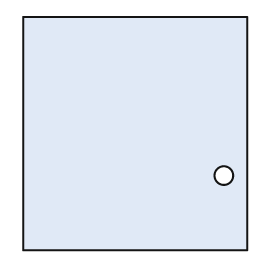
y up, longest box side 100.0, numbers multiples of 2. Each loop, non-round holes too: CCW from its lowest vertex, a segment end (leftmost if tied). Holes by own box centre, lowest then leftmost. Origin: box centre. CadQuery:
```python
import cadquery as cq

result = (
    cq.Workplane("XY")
    .moveTo(-48.0, -50.0)
    .lineTo(48.0, -50.0)
    .lineTo(48.0, 50.0)
    .lineTo(-48.0, 50.0)
    .close()
    .moveTo(38.0, -18.0)
    .circle(4.0)
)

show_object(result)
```